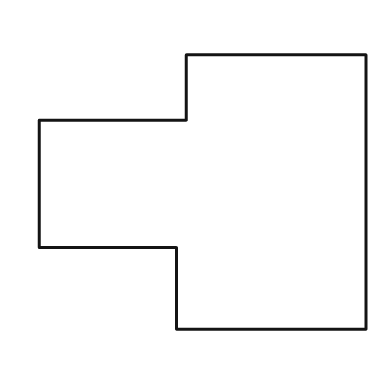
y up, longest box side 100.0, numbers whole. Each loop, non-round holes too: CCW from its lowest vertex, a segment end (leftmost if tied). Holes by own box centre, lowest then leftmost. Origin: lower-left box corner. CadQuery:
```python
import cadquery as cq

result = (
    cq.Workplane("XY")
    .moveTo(42.0, 0.0)
    .lineTo(100.0, 0.0)
    .lineTo(100.0, 84.0)
    .lineTo(45.0, 84.0)
    .lineTo(45.0, 64.0)
    .lineTo(0.0, 64.0)
    .lineTo(0.0, 25.0)
    .lineTo(42.0, 25.0)
    .close()
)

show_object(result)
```